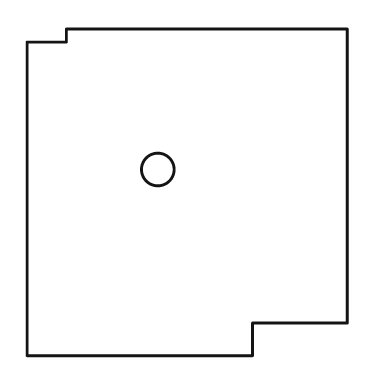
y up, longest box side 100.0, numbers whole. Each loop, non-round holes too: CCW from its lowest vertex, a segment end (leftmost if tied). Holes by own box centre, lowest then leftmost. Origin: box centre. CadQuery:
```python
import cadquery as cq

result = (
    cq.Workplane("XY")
    .moveTo(-49.0, -50.0)
    .lineTo(20.0, -50.0)
    .lineTo(20.0, -40.0)
    .lineTo(49.0, -40.0)
    .lineTo(49.0, 50.0)
    .lineTo(-37.0, 50.0)
    .lineTo(-37.0, 46.0)
    .lineTo(-49.0, 46.0)
    .close()
    .moveTo(-9.0, 7.0)
    .circle(5.0)
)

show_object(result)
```